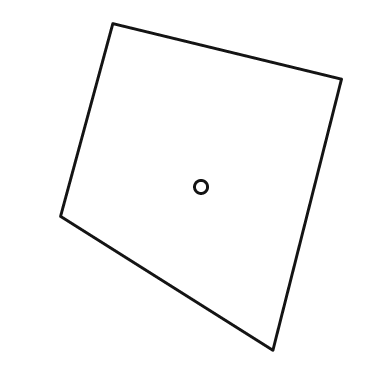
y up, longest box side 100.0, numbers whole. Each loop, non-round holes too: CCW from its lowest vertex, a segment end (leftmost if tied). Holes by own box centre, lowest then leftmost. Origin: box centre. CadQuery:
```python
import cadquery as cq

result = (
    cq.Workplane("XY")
    .moveTo(22.0, -50.0)
    .lineTo(43.0, 33.0)
    .lineTo(-27.0, 50.0)
    .lineTo(-43.0, -9.0)
    .close()
    .moveTo(0.0, 0.0)
    .circle(2.0)
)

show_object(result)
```